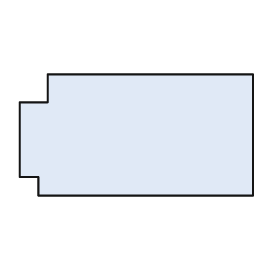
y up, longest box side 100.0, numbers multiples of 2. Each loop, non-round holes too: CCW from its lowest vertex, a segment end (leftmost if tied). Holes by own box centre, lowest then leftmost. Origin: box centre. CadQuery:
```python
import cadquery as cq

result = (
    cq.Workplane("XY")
    .moveTo(-42.0, -26.0)
    .lineTo(50.0, -26.0)
    .lineTo(50.0, 26.0)
    .lineTo(-38.0, 26.0)
    .lineTo(-38.0, 14.0)
    .lineTo(-50.0, 14.0)
    .lineTo(-50.0, -18.0)
    .lineTo(-42.0, -18.0)
    .close()
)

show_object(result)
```